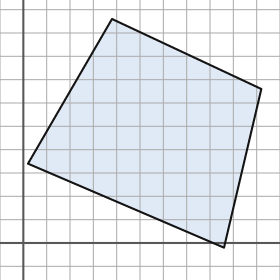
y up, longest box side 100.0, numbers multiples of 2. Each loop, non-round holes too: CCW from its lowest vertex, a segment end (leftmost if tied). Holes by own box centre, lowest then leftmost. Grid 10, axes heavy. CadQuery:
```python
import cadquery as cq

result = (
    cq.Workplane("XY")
    .moveTo(86.0, -2.0)
    .lineTo(102.0, 66.0)
    .lineTo(38.0, 96.0)
    .lineTo(2.0, 34.0)
    .close()
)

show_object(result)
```